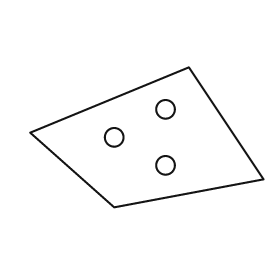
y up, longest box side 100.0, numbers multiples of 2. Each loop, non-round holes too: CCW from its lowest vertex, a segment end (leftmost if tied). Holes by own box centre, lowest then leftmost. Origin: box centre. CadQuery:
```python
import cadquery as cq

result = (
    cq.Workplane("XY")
    .moveTo(-14.0, -30.0)
    .lineTo(50.0, -18.0)
    .lineTo(18.0, 30.0)
    .lineTo(-50.0, 2.0)
    .close()
    .moveTo(8.0, -12.0)
    .circle(4.0)
    .moveTo(-14.0, 0.0)
    .circle(4.0)
    .moveTo(8.0, 12.0)
    .circle(4.0)
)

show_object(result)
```